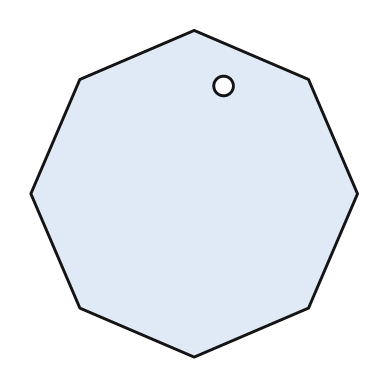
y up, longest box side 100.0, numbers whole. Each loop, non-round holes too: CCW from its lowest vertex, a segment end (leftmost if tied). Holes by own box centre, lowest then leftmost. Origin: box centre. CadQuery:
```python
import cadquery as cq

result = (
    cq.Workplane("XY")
    .moveTo(0.0, -50.0)
    .lineTo(35.0, -35.0)
    .lineTo(50.0, 0.0)
    .lineTo(35.0, 35.0)
    .lineTo(0.0, 50.0)
    .lineTo(-35.0, 35.0)
    .lineTo(-50.0, 0.0)
    .lineTo(-35.0, -35.0)
    .close()
    .moveTo(9.0, 33.0)
    .circle(3.0)
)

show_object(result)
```